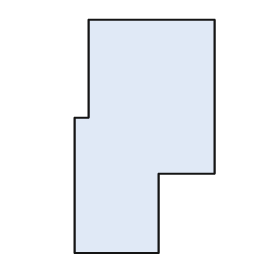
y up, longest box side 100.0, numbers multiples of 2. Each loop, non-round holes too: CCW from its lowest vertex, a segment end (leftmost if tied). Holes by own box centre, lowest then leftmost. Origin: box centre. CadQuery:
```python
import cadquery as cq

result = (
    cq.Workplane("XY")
    .moveTo(-30.0, -50.0)
    .lineTo(6.0, -50.0)
    .lineTo(6.0, -16.0)
    .lineTo(30.0, -16.0)
    .lineTo(30.0, 50.0)
    .lineTo(-24.0, 50.0)
    .lineTo(-24.0, 8.0)
    .lineTo(-30.0, 8.0)
    .close()
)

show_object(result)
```